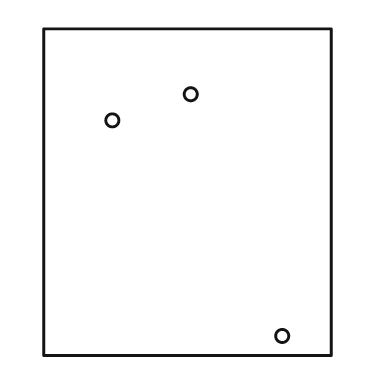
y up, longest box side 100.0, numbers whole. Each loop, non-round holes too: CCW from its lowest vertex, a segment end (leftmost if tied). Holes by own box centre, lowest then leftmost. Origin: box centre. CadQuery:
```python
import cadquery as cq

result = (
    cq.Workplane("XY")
    .moveTo(-44.0, -50.0)
    .lineTo(44.0, -50.0)
    .lineTo(44.0, 50.0)
    .lineTo(-44.0, 50.0)
    .close()
    .moveTo(29.0, -44.0)
    .circle(2.0)
    .moveTo(-23.0, 22.0)
    .circle(2.0)
    .moveTo(1.0, 30.0)
    .circle(2.0)
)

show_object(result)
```